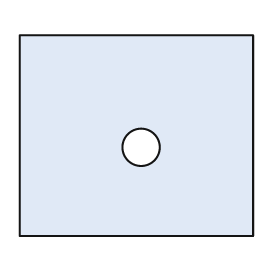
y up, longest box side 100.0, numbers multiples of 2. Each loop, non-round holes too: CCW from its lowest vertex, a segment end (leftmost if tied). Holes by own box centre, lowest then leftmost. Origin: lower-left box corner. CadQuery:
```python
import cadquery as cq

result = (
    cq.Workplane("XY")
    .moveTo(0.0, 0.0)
    .lineTo(100.0, 0.0)
    .lineTo(100.0, 86.0)
    .lineTo(0.0, 86.0)
    .close()
    .moveTo(52.0, 38.0)
    .circle(8.0)
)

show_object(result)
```